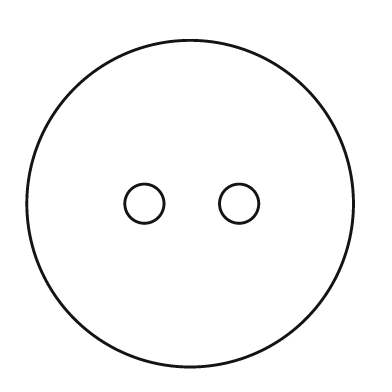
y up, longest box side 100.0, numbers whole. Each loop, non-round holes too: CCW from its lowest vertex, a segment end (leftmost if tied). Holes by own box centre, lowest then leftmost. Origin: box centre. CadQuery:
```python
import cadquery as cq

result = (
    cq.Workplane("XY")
    .moveTo(0.0, 0.0)
    .circle(50.0)
    .moveTo(-14.0, 0.0)
    .circle(6.0)
    .moveTo(15.0, 0.0)
    .circle(6.0)
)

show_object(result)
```